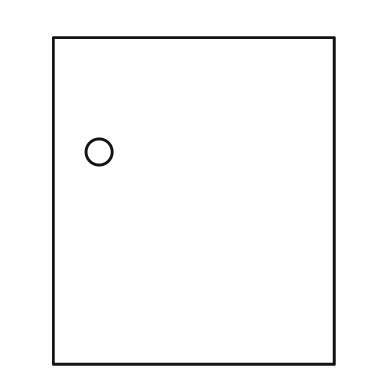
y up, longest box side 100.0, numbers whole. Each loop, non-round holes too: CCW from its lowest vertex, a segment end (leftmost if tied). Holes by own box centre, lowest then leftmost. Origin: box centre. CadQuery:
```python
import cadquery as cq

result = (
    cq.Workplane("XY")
    .moveTo(-43.0, -50.0)
    .lineTo(43.0, -50.0)
    .lineTo(43.0, 50.0)
    .lineTo(-43.0, 50.0)
    .close()
    .moveTo(-29.0, 15.0)
    .circle(4.0)
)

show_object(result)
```